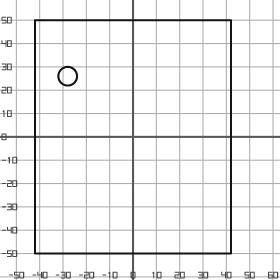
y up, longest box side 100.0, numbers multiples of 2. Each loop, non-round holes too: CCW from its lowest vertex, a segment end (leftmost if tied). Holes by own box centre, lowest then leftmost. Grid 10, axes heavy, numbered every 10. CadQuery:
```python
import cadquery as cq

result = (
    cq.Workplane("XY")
    .moveTo(-42.0, -50.0)
    .lineTo(42.0, -50.0)
    .lineTo(42.0, 50.0)
    .lineTo(-42.0, 50.0)
    .close()
    .moveTo(-28.0, 26.0)
    .circle(4.0)
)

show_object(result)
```